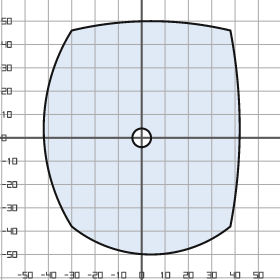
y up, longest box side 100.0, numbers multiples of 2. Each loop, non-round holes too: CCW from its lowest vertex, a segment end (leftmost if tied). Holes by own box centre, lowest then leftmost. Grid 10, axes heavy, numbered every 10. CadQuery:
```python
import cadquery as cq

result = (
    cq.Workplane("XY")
    .moveTo(-30.0, -38.0)
    .threePointArc((4.0, -50.0), (38.0, -38.0))
    .threePointArc((42.0, 4.0), (38.0, 46.0))
    .threePointArc((4.0, 50.0), (-30.0, 46.0))
    .threePointArc((-42.0, 4.0), (-30.0, -38.0))
    .close()
    .moveTo(0.0, 0.0)
    .circle(4.0)
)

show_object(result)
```